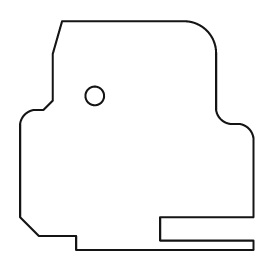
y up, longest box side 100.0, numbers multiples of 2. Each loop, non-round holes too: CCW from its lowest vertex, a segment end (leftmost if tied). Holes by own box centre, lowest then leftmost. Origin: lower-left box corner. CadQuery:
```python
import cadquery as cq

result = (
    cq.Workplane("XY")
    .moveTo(24.0, 0.0)
    .lineTo(100.0, 0.0)
    .lineTo(100.0, 4.0)
    .lineTo(60.0, 4.0)
    .lineTo(60.0, 14.0)
    .lineTo(100.0, 14.0)
    .lineTo(100.0, 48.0)
    .threePointArc((98.0, 52.0), (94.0, 54.0))
    .lineTo(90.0, 54.0)
    .threePointArc((86.0, 56.0), (84.0, 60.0))
    .lineTo(84.0, 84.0)
    .threePointArc((80.0, 94.0), (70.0, 98.0))
    .lineTo(18.0, 98.0)
    .lineTo(14.0, 84.0)
    .lineTo(14.0, 64.0)
    .lineTo(10.0, 60.0)
    .lineTo(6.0, 60.0)
    .threePointArc((2.0, 58.0), (0.0, 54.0))
    .lineTo(0.0, 14.0)
    .lineTo(8.0, 6.0)
    .lineTo(24.0, 6.0)
    .close()
    .moveTo(32.0, 66.0)
    .circle(4.0)
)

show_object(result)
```